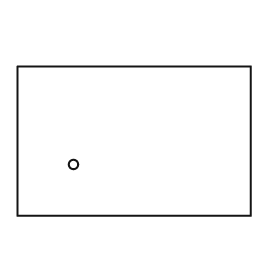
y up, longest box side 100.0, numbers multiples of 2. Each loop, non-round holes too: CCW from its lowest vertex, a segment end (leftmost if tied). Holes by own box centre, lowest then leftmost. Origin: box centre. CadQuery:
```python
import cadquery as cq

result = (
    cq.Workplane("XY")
    .moveTo(-50.0, -32.0)
    .lineTo(50.0, -32.0)
    .lineTo(50.0, 32.0)
    .lineTo(-50.0, 32.0)
    .close()
    .moveTo(-26.0, -10.0)
    .circle(2.0)
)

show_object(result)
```